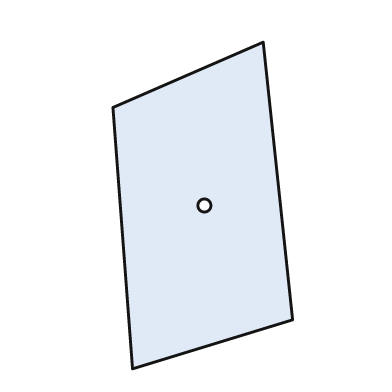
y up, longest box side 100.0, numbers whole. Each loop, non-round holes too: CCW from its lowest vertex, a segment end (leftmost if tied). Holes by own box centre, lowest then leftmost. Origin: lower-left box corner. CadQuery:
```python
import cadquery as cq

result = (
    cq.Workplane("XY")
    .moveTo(6.0, 0.0)
    .lineTo(55.0, 15.0)
    .lineTo(46.0, 100.0)
    .lineTo(0.0, 80.0)
    .close()
    .moveTo(28.0, 50.0)
    .circle(2.0)
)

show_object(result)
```